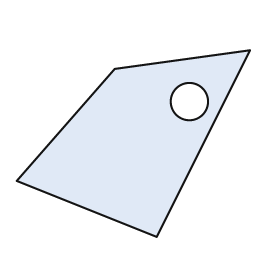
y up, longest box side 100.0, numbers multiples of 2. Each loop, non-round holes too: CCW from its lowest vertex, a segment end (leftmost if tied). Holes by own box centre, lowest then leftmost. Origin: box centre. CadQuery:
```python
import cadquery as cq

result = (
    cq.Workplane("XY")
    .moveTo(10.0, -40.0)
    .lineTo(50.0, 40.0)
    .lineTo(-8.0, 32.0)
    .lineTo(-50.0, -16.0)
    .close()
    .moveTo(24.0, 18.0)
    .circle(8.0)
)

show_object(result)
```